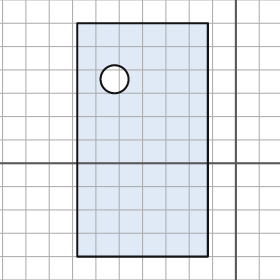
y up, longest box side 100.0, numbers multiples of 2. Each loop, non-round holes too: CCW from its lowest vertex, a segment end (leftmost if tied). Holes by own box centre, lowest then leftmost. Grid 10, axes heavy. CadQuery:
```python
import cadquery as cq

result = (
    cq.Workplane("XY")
    .moveTo(-68.0, -40.0)
    .lineTo(-12.0, -40.0)
    .lineTo(-12.0, 60.0)
    .lineTo(-68.0, 60.0)
    .close()
    .moveTo(-52.0, 36.0)
    .circle(6.0)
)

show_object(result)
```